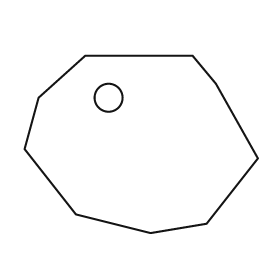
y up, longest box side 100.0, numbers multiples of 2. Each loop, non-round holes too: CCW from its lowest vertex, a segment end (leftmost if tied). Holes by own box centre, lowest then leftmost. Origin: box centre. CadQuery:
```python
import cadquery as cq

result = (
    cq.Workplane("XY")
    .moveTo(4.0, -38.0)
    .lineTo(28.0, -34.0)
    .lineTo(50.0, -6.0)
    .lineTo(32.0, 26.0)
    .lineTo(22.0, 38.0)
    .lineTo(-24.0, 38.0)
    .lineTo(-44.0, 20.0)
    .lineTo(-50.0, -2.0)
    .lineTo(-28.0, -30.0)
    .close()
    .moveTo(-14.0, 20.0)
    .circle(6.0)
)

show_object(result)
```